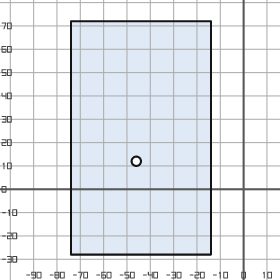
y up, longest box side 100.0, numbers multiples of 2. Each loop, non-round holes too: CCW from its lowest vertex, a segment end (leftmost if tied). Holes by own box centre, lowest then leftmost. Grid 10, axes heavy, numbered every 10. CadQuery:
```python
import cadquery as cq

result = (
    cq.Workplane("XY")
    .moveTo(-74.0, -28.0)
    .lineTo(-14.0, -28.0)
    .lineTo(-14.0, 72.0)
    .lineTo(-74.0, 72.0)
    .close()
    .moveTo(-46.0, 12.0)
    .circle(2.0)
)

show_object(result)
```